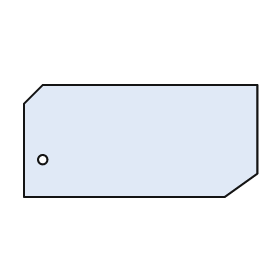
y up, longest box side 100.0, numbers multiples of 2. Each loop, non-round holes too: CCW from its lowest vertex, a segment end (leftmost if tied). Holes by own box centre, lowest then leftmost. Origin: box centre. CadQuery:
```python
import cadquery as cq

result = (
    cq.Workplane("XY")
    .moveTo(-50.0, -24.0)
    .lineTo(36.0, -24.0)
    .lineTo(50.0, -14.0)
    .lineTo(50.0, 24.0)
    .lineTo(-42.0, 24.0)
    .lineTo(-50.0, 16.0)
    .close()
    .moveTo(-42.0, -8.0)
    .circle(2.0)
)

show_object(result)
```